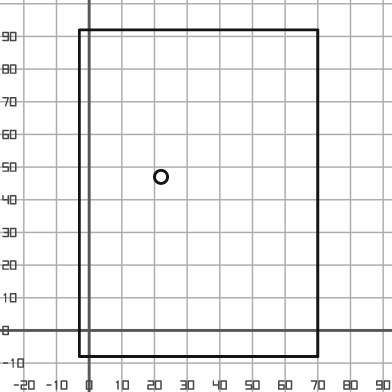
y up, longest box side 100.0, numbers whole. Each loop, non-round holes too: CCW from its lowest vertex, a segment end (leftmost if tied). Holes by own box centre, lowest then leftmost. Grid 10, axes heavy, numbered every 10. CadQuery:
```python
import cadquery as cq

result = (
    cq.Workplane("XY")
    .moveTo(-3.0, -8.0)
    .lineTo(70.0, -8.0)
    .lineTo(70.0, 92.0)
    .lineTo(-3.0, 92.0)
    .close()
    .moveTo(22.0, 47.0)
    .circle(2.0)
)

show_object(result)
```